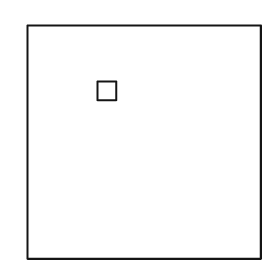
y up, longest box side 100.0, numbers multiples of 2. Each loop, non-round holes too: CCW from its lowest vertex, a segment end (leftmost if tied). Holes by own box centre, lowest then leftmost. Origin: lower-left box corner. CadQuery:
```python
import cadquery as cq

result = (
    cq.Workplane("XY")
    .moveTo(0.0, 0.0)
    .lineTo(100.0, 0.0)
    .lineTo(100.0, 100.0)
    .lineTo(0.0, 100.0)
    .close()
    .moveTo(30.0, 68.0)
    .lineTo(38.0, 68.0)
    .lineTo(38.0, 76.0)
    .lineTo(30.0, 76.0)
    .close()
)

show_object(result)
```